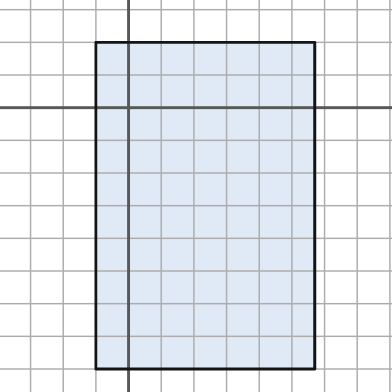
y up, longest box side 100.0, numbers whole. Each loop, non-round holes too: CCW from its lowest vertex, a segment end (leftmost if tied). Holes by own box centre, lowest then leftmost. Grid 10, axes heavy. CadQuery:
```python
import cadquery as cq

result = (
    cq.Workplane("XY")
    .moveTo(-10.0, -80.0)
    .lineTo(57.0, -80.0)
    .lineTo(57.0, 20.0)
    .lineTo(-10.0, 20.0)
    .close()
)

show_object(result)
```